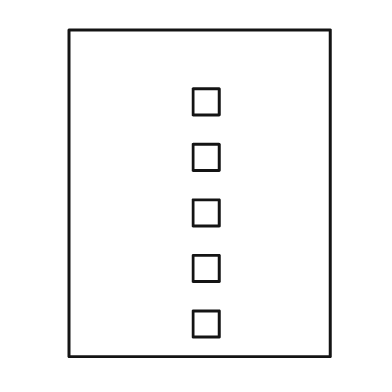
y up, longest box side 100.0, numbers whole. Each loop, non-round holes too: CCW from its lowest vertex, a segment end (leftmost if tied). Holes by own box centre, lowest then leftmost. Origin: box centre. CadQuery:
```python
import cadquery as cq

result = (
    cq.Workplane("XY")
    .moveTo(-40.0, -50.0)
    .lineTo(40.0, -50.0)
    .lineTo(40.0, 50.0)
    .lineTo(-40.0, 50.0)
    .close()
    .moveTo(-2.0, -44.0)
    .lineTo(6.0, -44.0)
    .lineTo(6.0, -36.0)
    .lineTo(-2.0, -36.0)
    .close()
    .moveTo(-2.0, -27.0)
    .lineTo(6.0, -27.0)
    .lineTo(6.0, -19.0)
    .lineTo(-2.0, -19.0)
    .close()
    .moveTo(-2.0, -10.0)
    .lineTo(6.0, -10.0)
    .lineTo(6.0, -2.0)
    .lineTo(-2.0, -2.0)
    .close()
    .moveTo(-2.0, 7.0)
    .lineTo(6.0, 7.0)
    .lineTo(6.0, 15.0)
    .lineTo(-2.0, 15.0)
    .close()
    .moveTo(-2.0, 24.0)
    .lineTo(6.0, 24.0)
    .lineTo(6.0, 32.0)
    .lineTo(-2.0, 32.0)
    .close()
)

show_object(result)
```